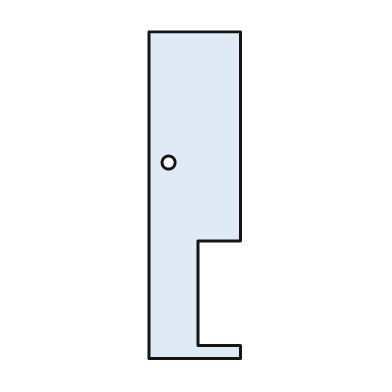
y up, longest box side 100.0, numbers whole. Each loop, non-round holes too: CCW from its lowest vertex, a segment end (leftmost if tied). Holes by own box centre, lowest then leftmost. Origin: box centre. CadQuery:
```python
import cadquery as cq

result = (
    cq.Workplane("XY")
    .moveTo(-14.0, -50.0)
    .lineTo(14.0, -50.0)
    .lineTo(14.0, -46.0)
    .lineTo(1.0, -46.0)
    .lineTo(1.0, -14.0)
    .lineTo(14.0, -14.0)
    .lineTo(14.0, 50.0)
    .lineTo(-14.0, 50.0)
    .close()
    .moveTo(-8.0, 10.0)
    .circle(2.0)
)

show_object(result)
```